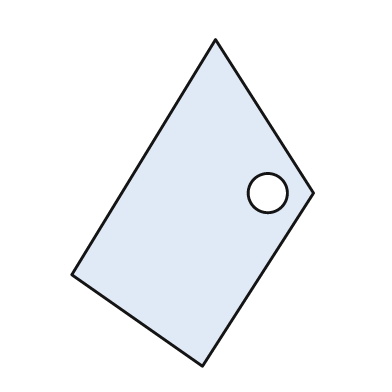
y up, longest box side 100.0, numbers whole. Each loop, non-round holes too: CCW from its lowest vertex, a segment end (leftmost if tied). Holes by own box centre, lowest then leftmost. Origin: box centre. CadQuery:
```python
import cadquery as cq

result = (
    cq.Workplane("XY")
    .moveTo(3.0, -50.0)
    .lineTo(37.0, 3.0)
    .lineTo(7.0, 50.0)
    .lineTo(-37.0, -22.0)
    .close()
    .moveTo(23.0, 3.0)
    .circle(6.0)
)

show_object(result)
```